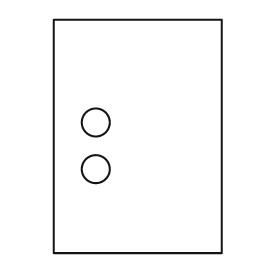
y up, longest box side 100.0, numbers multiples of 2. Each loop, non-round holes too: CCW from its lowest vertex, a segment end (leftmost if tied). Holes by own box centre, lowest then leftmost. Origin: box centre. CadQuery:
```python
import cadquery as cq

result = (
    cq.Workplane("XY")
    .moveTo(-36.0, -50.0)
    .lineTo(36.0, -50.0)
    .lineTo(36.0, 50.0)
    .lineTo(-36.0, 50.0)
    .close()
    .moveTo(-18.0, -14.0)
    .circle(6.0)
    .moveTo(-18.0, 6.0)
    .circle(6.0)
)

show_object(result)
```